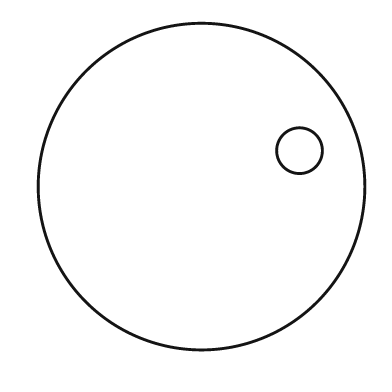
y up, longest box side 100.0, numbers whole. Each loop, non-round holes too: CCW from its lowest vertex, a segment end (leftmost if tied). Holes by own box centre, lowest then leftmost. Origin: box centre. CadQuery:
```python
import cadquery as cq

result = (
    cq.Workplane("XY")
    .moveTo(0.0, 0.0)
    .circle(50.0)
    .moveTo(30.0, 11.0)
    .circle(7.0)
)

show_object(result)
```